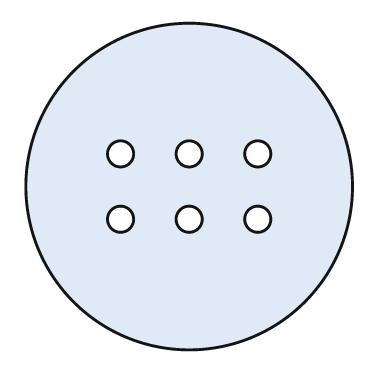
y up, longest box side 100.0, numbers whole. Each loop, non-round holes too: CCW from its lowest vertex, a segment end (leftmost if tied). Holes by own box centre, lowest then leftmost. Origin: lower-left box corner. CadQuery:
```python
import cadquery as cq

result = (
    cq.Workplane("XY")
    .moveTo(50.0, 50.0)
    .circle(50.0)
    .moveTo(29.0, 40.0)
    .circle(4.0)
    .moveTo(50.0, 40.0)
    .circle(4.0)
    .moveTo(71.0, 40.0)
    .circle(4.0)
    .moveTo(29.0, 60.0)
    .circle(4.0)
    .moveTo(50.0, 60.0)
    .circle(4.0)
    .moveTo(71.0, 60.0)
    .circle(4.0)
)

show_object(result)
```